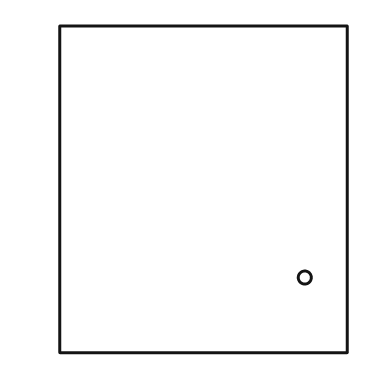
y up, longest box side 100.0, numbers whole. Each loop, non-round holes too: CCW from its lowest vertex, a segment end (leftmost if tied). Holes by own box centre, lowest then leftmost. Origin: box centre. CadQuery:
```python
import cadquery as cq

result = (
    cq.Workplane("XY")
    .moveTo(-44.0, -50.0)
    .lineTo(44.0, -50.0)
    .lineTo(44.0, 50.0)
    .lineTo(-44.0, 50.0)
    .close()
    .moveTo(31.0, -27.0)
    .circle(2.0)
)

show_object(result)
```